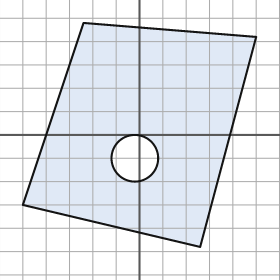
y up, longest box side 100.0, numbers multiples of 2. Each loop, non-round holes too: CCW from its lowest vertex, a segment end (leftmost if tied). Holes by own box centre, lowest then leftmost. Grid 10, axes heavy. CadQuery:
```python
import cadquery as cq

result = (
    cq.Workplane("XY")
    .moveTo(26.0, -48.0)
    .lineTo(50.0, 42.0)
    .lineTo(-24.0, 48.0)
    .lineTo(-50.0, -30.0)
    .close()
    .moveTo(-2.0, -10.0)
    .circle(10.0)
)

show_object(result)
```